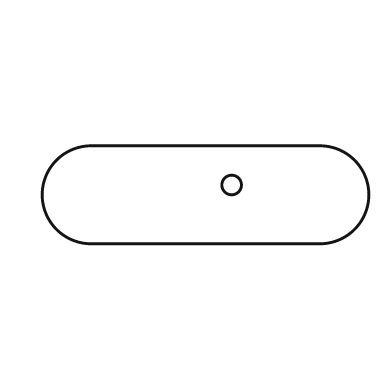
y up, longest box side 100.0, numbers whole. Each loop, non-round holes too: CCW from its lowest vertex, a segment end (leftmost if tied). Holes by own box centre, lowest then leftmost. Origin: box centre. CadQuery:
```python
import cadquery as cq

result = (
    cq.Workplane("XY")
    .moveTo(-35.0, -15.0)
    .lineTo(35.0, -15.0)
    .threePointArc((50.0, 0.0), (35.0, 15.0))
    .lineTo(-35.0, 15.0)
    .threePointArc((-50.0, 0.0), (-35.0, -15.0))
    .close()
    .moveTo(8.0, 3.0)
    .circle(3.0)
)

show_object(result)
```